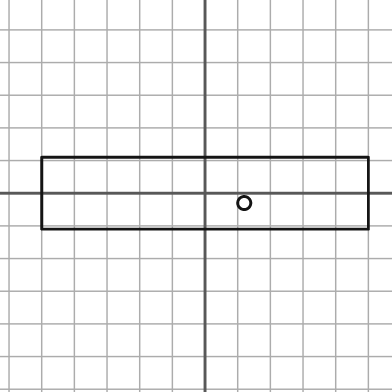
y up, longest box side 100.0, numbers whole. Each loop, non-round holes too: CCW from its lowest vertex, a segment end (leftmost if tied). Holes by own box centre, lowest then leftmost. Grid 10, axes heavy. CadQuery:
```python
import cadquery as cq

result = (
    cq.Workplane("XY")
    .moveTo(-50.0, -11.0)
    .lineTo(50.0, -11.0)
    .lineTo(50.0, 11.0)
    .lineTo(-50.0, 11.0)
    .close()
    .moveTo(12.0, -3.0)
    .circle(2.0)
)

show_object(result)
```